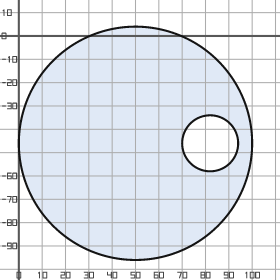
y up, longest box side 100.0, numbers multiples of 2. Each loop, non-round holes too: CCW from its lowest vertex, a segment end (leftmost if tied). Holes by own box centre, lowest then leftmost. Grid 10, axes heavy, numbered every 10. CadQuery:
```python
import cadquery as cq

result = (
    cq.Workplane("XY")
    .moveTo(50.0, -46.0)
    .circle(50.0)
    .moveTo(82.0, -46.0)
    .circle(12.0)
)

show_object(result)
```